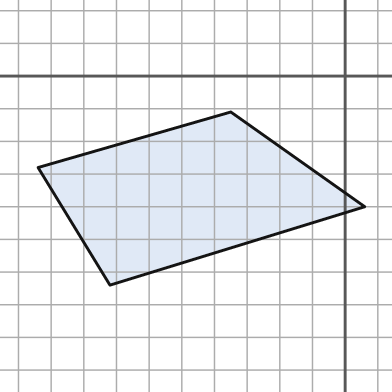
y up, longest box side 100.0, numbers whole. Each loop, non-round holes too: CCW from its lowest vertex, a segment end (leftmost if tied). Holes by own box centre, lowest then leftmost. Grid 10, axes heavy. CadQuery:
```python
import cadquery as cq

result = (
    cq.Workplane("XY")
    .moveTo(-72.0, -64.0)
    .lineTo(6.0, -40.0)
    .lineTo(-35.0, -11.0)
    .lineTo(-94.0, -28.0)
    .close()
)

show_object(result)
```